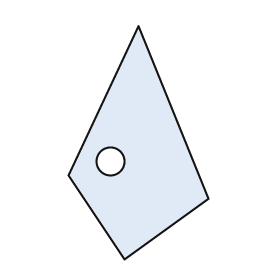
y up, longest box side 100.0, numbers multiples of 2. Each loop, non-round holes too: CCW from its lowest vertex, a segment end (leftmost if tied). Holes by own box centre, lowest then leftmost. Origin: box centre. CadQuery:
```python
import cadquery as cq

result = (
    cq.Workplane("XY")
    .moveTo(-6.0, -50.0)
    .lineTo(30.0, -24.0)
    .lineTo(0.0, 50.0)
    .lineTo(-30.0, -14.0)
    .close()
    .moveTo(-12.0, -8.0)
    .circle(6.0)
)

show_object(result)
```